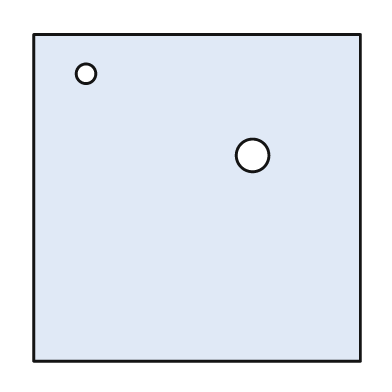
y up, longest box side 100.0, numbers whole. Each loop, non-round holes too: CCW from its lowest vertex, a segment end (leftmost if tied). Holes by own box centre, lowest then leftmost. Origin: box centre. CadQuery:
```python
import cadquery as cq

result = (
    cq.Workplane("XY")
    .moveTo(-50.0, -50.0)
    .lineTo(50.0, -50.0)
    .lineTo(50.0, 50.0)
    .lineTo(-50.0, 50.0)
    .close()
    .moveTo(17.0, 13.0)
    .circle(5.0)
    .moveTo(-34.0, 38.0)
    .circle(3.0)
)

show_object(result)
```